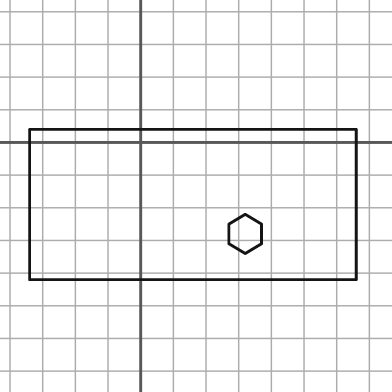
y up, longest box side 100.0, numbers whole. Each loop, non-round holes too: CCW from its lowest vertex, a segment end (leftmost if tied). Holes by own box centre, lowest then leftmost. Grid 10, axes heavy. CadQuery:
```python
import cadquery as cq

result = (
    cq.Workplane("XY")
    .moveTo(-34.0, -42.0)
    .lineTo(66.0, -42.0)
    .lineTo(66.0, 4.0)
    .lineTo(-34.0, 4.0)
    .close()
    .moveTo(32.0, -34.0)
    .lineTo(37.0, -31.0)
    .lineTo(37.0, -25.0)
    .lineTo(32.0, -22.0)
    .lineTo(27.0, -25.0)
    .lineTo(27.0, -31.0)
    .close()
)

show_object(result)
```